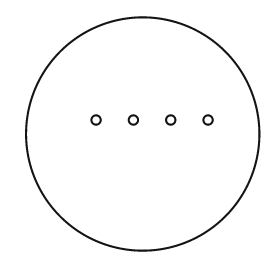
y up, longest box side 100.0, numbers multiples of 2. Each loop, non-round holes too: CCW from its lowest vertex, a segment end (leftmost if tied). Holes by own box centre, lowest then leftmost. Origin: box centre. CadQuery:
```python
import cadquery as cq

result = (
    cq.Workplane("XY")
    .moveTo(0.0, 0.0)
    .circle(50.0)
    .moveTo(-20.0, 6.0)
    .circle(2.0)
    .moveTo(-4.0, 6.0)
    .circle(2.0)
    .moveTo(12.0, 6.0)
    .circle(2.0)
    .moveTo(28.0, 6.0)
    .circle(2.0)
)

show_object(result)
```